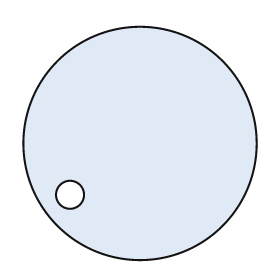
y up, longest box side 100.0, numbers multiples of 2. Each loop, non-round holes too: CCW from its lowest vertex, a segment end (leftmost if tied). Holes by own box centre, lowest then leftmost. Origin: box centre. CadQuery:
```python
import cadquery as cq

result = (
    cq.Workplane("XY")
    .moveTo(0.0, 0.0)
    .circle(50.0)
    .moveTo(-30.0, -22.0)
    .circle(6.0)
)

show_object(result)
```